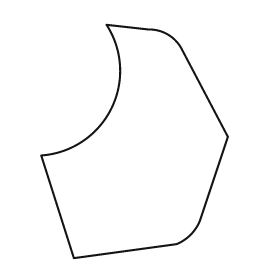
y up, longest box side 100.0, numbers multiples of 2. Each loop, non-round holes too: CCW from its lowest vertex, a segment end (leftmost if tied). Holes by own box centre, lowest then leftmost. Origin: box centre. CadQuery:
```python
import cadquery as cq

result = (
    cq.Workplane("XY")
    .moveTo(-26.0, -50.0)
    .lineTo(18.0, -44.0)
    .threePointArc((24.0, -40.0), (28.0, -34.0))
    .lineTo(40.0, 2.0)
    .lineTo(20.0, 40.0)
    .threePointArc((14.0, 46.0), (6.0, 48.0))
    .lineTo(-12.0, 50.0)
    .threePointArc((-10.0, 14.0), (-40.0, -6.0))
    .close()
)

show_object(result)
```